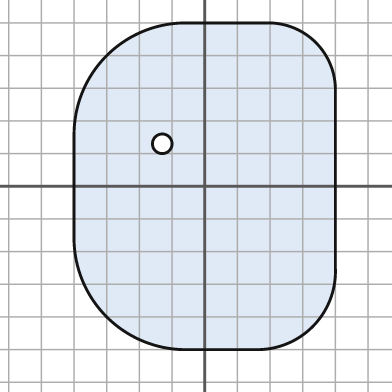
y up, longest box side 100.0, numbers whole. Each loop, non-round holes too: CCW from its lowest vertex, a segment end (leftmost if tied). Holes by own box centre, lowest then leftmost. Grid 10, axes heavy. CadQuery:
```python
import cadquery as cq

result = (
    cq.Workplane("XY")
    .moveTo(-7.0, -50.0)
    .lineTo(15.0, -50.0)
    .threePointArc((33.0, -43.0), (40.0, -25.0))
    .lineTo(40.0, 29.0)
    .threePointArc((34.0, 44.0), (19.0, 50.0))
    .lineTo(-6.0, 50.0)
    .threePointArc((-30.0, 40.0), (-40.0, 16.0))
    .lineTo(-40.0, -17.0)
    .threePointArc((-30.0, -40.0), (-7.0, -50.0))
    .close()
    .moveTo(-13.0, 13.0)
    .circle(3.0)
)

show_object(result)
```